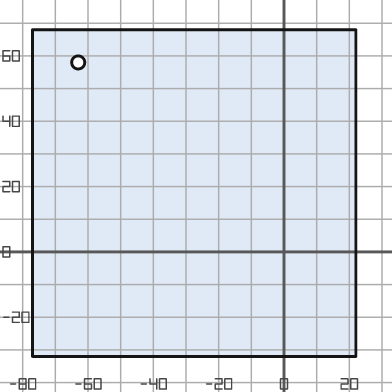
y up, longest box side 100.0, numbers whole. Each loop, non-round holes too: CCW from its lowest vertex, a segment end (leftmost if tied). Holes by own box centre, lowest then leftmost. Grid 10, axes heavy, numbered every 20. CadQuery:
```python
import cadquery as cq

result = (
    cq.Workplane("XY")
    .moveTo(-77.0, -32.0)
    .lineTo(22.0, -32.0)
    .lineTo(22.0, 68.0)
    .lineTo(-77.0, 68.0)
    .close()
    .moveTo(-63.0, 58.0)
    .circle(2.0)
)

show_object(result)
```